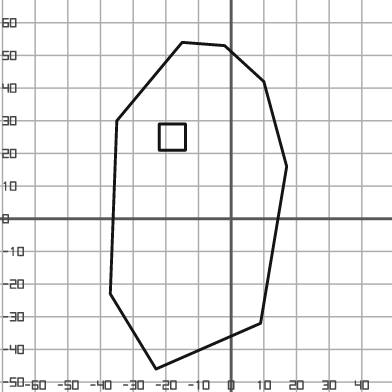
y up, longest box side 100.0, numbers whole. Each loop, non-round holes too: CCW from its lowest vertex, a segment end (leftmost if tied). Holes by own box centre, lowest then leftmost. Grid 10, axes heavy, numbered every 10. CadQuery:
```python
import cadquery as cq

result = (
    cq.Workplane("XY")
    .moveTo(-23.0, -46.0)
    .lineTo(9.0, -32.0)
    .lineTo(17.0, 16.0)
    .lineTo(10.0, 42.0)
    .lineTo(-2.0, 53.0)
    .lineTo(-15.0, 54.0)
    .lineTo(-35.0, 30.0)
    .lineTo(-37.0, -23.0)
    .close()
    .moveTo(-22.0, 21.0)
    .lineTo(-14.0, 21.0)
    .lineTo(-14.0, 29.0)
    .lineTo(-22.0, 29.0)
    .close()
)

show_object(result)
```